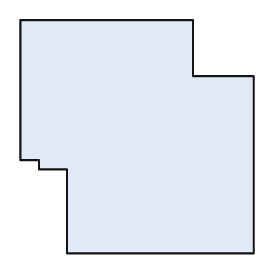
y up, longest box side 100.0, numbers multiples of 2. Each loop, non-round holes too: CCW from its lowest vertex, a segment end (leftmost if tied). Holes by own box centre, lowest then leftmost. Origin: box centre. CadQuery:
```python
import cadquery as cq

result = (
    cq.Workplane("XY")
    .moveTo(-30.0, -50.0)
    .lineTo(50.0, -50.0)
    .lineTo(50.0, 26.0)
    .lineTo(24.0, 26.0)
    .lineTo(24.0, 50.0)
    .lineTo(-50.0, 50.0)
    .lineTo(-50.0, -10.0)
    .lineTo(-42.0, -10.0)
    .lineTo(-42.0, -14.0)
    .lineTo(-30.0, -14.0)
    .close()
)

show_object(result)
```